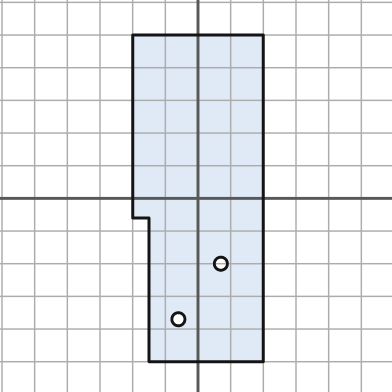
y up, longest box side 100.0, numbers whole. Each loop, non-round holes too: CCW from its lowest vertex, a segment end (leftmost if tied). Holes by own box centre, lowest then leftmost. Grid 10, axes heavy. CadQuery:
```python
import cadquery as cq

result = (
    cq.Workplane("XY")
    .moveTo(-15.0, -50.0)
    .lineTo(20.0, -50.0)
    .lineTo(20.0, 50.0)
    .lineTo(-20.0, 50.0)
    .lineTo(-20.0, -6.0)
    .lineTo(-15.0, -6.0)
    .close()
    .moveTo(-6.0, -37.0)
    .circle(2.0)
    .moveTo(7.0, -20.0)
    .circle(2.0)
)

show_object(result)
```